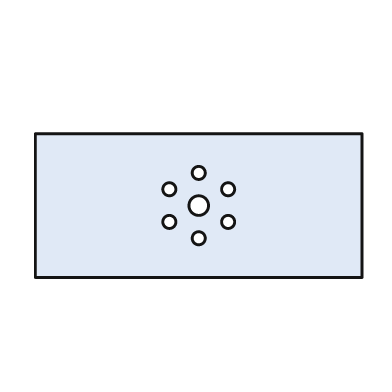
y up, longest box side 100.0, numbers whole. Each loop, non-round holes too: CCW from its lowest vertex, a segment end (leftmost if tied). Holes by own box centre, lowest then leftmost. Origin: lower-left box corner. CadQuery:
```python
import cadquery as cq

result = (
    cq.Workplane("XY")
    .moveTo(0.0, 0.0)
    .lineTo(100.0, 0.0)
    .lineTo(100.0, 44.0)
    .lineTo(0.0, 44.0)
    .close()
    .moveTo(50.0, 12.0)
    .circle(2.0)
    .moveTo(41.0, 17.0)
    .circle(2.0)
    .moveTo(59.0, 17.0)
    .circle(2.0)
    .moveTo(50.0, 22.0)
    .circle(3.0)
    .moveTo(41.0, 27.0)
    .circle(2.0)
    .moveTo(59.0, 27.0)
    .circle(2.0)
    .moveTo(50.0, 32.0)
    .circle(2.0)
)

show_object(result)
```